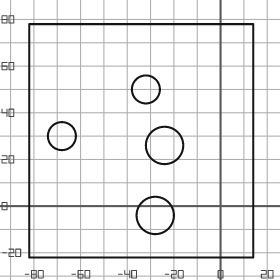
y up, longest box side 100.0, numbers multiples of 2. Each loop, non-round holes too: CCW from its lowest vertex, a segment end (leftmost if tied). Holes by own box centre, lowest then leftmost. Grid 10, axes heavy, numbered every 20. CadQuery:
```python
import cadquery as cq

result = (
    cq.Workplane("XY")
    .moveTo(-82.0, -22.0)
    .lineTo(14.0, -22.0)
    .lineTo(14.0, 78.0)
    .lineTo(-82.0, 78.0)
    .close()
    .moveTo(-28.0, -4.0)
    .circle(8.0)
    .moveTo(-24.0, 26.0)
    .circle(8.0)
    .moveTo(-68.0, 30.0)
    .circle(6.0)
    .moveTo(-32.0, 50.0)
    .circle(6.0)
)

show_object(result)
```